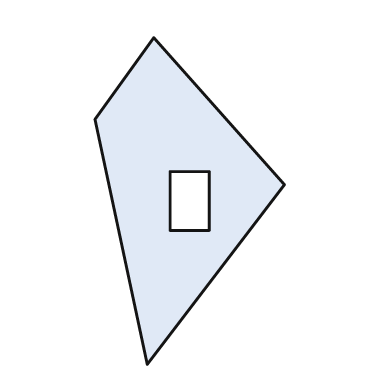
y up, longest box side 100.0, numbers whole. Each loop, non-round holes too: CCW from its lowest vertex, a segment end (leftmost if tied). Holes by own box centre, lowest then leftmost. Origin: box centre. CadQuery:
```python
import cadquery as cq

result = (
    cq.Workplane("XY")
    .moveTo(-13.0, -50.0)
    .lineTo(29.0, 5.0)
    .lineTo(-11.0, 50.0)
    .lineTo(-29.0, 25.0)
    .close()
    .moveTo(-6.0, -9.0)
    .lineTo(6.0, -9.0)
    .lineTo(6.0, 9.0)
    .lineTo(-6.0, 9.0)
    .close()
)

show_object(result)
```